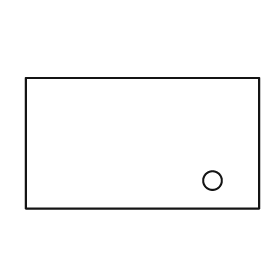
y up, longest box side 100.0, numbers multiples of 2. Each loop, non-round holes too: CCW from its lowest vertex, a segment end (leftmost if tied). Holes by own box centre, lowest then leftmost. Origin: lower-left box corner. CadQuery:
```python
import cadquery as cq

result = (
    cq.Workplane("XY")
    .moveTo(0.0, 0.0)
    .lineTo(100.0, 0.0)
    .lineTo(100.0, 56.0)
    .lineTo(0.0, 56.0)
    .close()
    .moveTo(80.0, 12.0)
    .circle(4.0)
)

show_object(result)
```